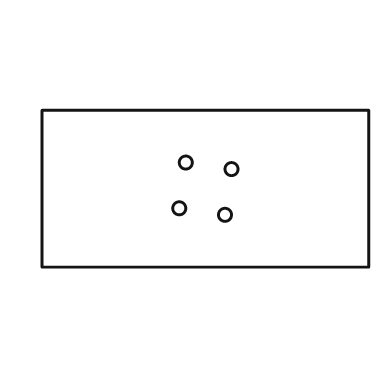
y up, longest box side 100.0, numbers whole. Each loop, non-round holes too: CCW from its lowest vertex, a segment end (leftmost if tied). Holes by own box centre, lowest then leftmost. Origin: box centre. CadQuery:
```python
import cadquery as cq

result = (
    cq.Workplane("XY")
    .moveTo(-50.0, -24.0)
    .lineTo(50.0, -24.0)
    .lineTo(50.0, 24.0)
    .lineTo(-50.0, 24.0)
    .close()
    .moveTo(6.0, -8.0)
    .circle(2.0)
    .moveTo(-8.0, -6.0)
    .circle(2.0)
    .moveTo(8.0, 6.0)
    .circle(2.0)
    .moveTo(-6.0, 8.0)
    .circle(2.0)
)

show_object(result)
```